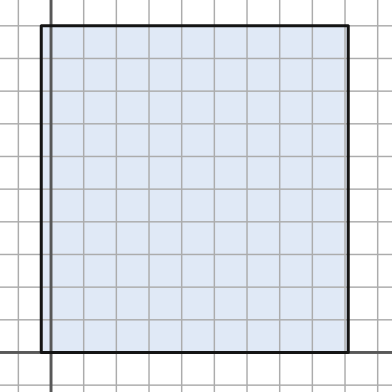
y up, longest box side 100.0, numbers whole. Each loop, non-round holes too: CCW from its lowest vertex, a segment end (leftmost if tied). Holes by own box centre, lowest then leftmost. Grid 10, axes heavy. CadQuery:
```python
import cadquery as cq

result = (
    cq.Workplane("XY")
    .moveTo(-3.0, 0.0)
    .lineTo(91.0, 0.0)
    .lineTo(91.0, 100.0)
    .lineTo(-3.0, 100.0)
    .close()
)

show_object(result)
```